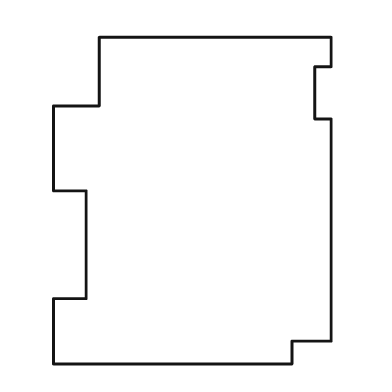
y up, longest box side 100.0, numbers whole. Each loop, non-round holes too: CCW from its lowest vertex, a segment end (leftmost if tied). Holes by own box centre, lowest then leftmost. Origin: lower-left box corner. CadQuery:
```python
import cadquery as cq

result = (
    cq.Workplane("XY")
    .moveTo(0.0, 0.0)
    .lineTo(73.0, 0.0)
    .lineTo(73.0, 7.0)
    .lineTo(85.0, 7.0)
    .lineTo(85.0, 75.0)
    .lineTo(80.0, 75.0)
    .lineTo(80.0, 91.0)
    .lineTo(85.0, 91.0)
    .lineTo(85.0, 100.0)
    .lineTo(14.0, 100.0)
    .lineTo(14.0, 79.0)
    .lineTo(0.0, 79.0)
    .lineTo(0.0, 53.0)
    .lineTo(10.0, 53.0)
    .lineTo(10.0, 20.0)
    .lineTo(0.0, 20.0)
    .close()
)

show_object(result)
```